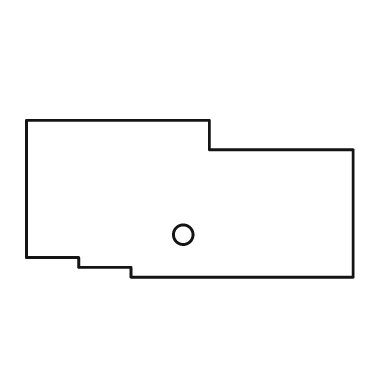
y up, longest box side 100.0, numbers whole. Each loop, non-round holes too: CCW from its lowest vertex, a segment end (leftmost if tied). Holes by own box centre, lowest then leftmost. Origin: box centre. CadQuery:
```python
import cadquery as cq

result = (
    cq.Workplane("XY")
    .moveTo(-18.0, -24.0)
    .lineTo(50.0, -24.0)
    .lineTo(50.0, 15.0)
    .lineTo(6.0, 15.0)
    .lineTo(6.0, 24.0)
    .lineTo(-50.0, 24.0)
    .lineTo(-50.0, -18.0)
    .lineTo(-34.0, -18.0)
    .lineTo(-34.0, -21.0)
    .lineTo(-18.0, -21.0)
    .close()
    .moveTo(-2.0, -11.0)
    .circle(3.0)
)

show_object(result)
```